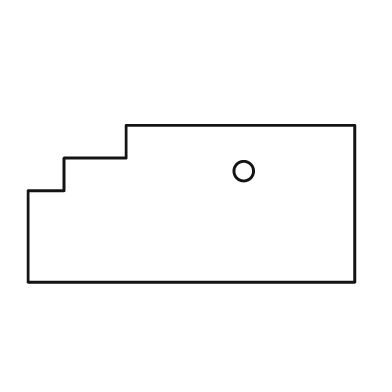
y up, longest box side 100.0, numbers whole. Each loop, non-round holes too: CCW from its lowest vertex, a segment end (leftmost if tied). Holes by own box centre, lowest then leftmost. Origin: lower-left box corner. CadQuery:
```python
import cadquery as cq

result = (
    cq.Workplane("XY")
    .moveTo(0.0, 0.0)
    .lineTo(100.0, 0.0)
    .lineTo(100.0, 48.0)
    .lineTo(30.0, 48.0)
    .lineTo(30.0, 38.0)
    .lineTo(11.0, 38.0)
    .lineTo(11.0, 28.0)
    .lineTo(0.0, 28.0)
    .close()
    .moveTo(66.0, 34.0)
    .circle(3.0)
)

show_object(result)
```